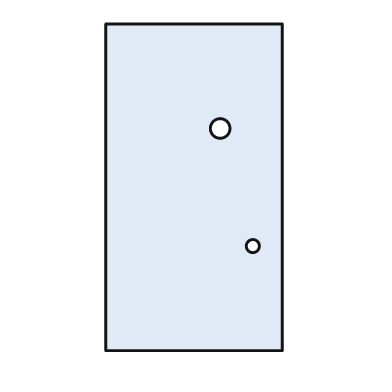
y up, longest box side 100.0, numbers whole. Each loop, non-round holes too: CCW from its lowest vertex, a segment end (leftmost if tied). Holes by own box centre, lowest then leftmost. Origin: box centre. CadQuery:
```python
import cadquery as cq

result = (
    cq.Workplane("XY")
    .moveTo(-27.0, -50.0)
    .lineTo(27.0, -50.0)
    .lineTo(27.0, 50.0)
    .lineTo(-27.0, 50.0)
    .close()
    .moveTo(18.0, -18.0)
    .circle(2.0)
    .moveTo(8.0, 18.0)
    .circle(3.0)
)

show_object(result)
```